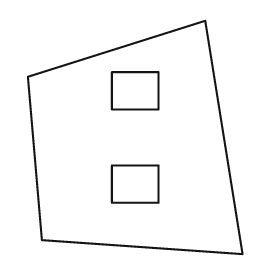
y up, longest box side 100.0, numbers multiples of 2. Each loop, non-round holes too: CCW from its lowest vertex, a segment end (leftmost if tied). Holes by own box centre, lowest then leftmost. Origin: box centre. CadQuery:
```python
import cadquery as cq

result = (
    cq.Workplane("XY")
    .moveTo(46.0, -50.0)
    .lineTo(30.0, 50.0)
    .lineTo(-46.0, 26.0)
    .lineTo(-40.0, -44.0)
    .close()
    .moveTo(-10.0, -28.0)
    .lineTo(10.0, -28.0)
    .lineTo(10.0, -12.0)
    .lineTo(-10.0, -12.0)
    .close()
    .moveTo(-10.0, 12.0)
    .lineTo(10.0, 12.0)
    .lineTo(10.0, 28.0)
    .lineTo(-10.0, 28.0)
    .close()
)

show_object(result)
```